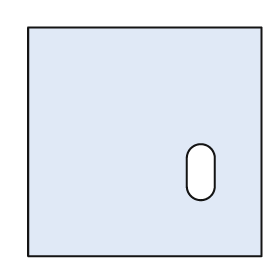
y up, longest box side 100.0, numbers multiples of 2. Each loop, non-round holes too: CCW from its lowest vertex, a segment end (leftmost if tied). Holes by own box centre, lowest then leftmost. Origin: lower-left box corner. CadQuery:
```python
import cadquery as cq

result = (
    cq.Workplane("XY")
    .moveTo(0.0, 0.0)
    .lineTo(100.0, 0.0)
    .lineTo(100.0, 98.0)
    .lineTo(0.0, 98.0)
    .close()
    .moveTo(68.0, 30.0)
    .threePointArc((74.0, 24.0), (80.0, 30.0))
    .lineTo(80.0, 42.0)
    .threePointArc((74.0, 48.0), (68.0, 42.0))
    .close()
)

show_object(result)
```